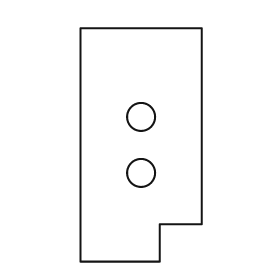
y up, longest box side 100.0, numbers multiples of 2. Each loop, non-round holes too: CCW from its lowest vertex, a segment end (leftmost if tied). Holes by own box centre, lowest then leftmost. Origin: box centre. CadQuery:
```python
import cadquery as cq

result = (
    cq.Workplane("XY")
    .moveTo(-26.0, -50.0)
    .lineTo(8.0, -50.0)
    .lineTo(8.0, -34.0)
    .lineTo(26.0, -34.0)
    .lineTo(26.0, 50.0)
    .lineTo(-26.0, 50.0)
    .close()
    .moveTo(0.0, -12.0)
    .circle(6.0)
    .moveTo(0.0, 12.0)
    .circle(6.0)
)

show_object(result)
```